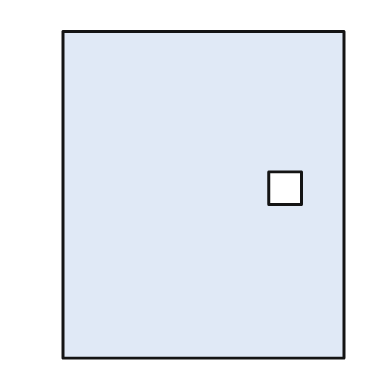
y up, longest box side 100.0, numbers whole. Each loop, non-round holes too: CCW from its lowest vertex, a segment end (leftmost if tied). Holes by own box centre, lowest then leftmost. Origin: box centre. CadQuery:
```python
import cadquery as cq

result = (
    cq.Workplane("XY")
    .moveTo(-43.0, -50.0)
    .lineTo(43.0, -50.0)
    .lineTo(43.0, 50.0)
    .lineTo(-43.0, 50.0)
    .close()
    .moveTo(20.0, -3.0)
    .lineTo(30.0, -3.0)
    .lineTo(30.0, 7.0)
    .lineTo(20.0, 7.0)
    .close()
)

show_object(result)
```